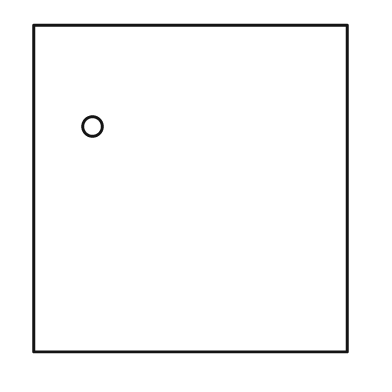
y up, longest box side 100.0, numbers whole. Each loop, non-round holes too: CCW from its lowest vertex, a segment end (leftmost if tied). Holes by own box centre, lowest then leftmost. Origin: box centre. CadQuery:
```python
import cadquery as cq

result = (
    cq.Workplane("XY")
    .moveTo(-48.0, -50.0)
    .lineTo(48.0, -50.0)
    .lineTo(48.0, 50.0)
    .lineTo(-48.0, 50.0)
    .close()
    .moveTo(-30.0, 19.0)
    .circle(3.0)
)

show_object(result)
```